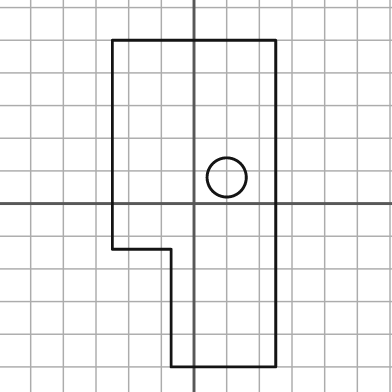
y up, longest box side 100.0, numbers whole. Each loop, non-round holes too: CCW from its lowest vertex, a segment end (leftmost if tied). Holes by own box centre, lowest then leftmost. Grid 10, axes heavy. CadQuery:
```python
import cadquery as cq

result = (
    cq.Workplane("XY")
    .moveTo(-7.0, -50.0)
    .lineTo(25.0, -50.0)
    .lineTo(25.0, 50.0)
    .lineTo(-25.0, 50.0)
    .lineTo(-25.0, -14.0)
    .lineTo(-7.0, -14.0)
    .close()
    .moveTo(10.0, 8.0)
    .circle(6.0)
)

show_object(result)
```